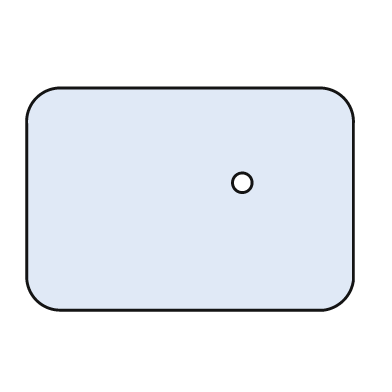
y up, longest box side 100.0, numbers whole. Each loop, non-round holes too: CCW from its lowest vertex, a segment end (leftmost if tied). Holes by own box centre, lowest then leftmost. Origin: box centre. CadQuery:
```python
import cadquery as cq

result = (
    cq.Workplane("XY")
    .moveTo(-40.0, -34.0)
    .lineTo(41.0, -34.0)
    .threePointArc((47.0, -31.0), (50.0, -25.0))
    .lineTo(50.0, 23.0)
    .threePointArc((47.0, 31.0), (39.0, 34.0))
    .lineTo(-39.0, 34.0)
    .threePointArc((-47.0, 31.0), (-50.0, 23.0))
    .lineTo(-50.0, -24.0)
    .threePointArc((-47.0, -31.0), (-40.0, -34.0))
    .close()
    .moveTo(16.0, 5.0)
    .circle(3.0)
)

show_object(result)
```